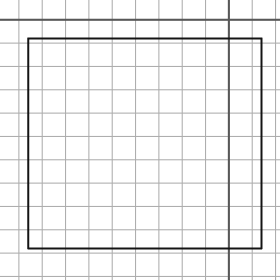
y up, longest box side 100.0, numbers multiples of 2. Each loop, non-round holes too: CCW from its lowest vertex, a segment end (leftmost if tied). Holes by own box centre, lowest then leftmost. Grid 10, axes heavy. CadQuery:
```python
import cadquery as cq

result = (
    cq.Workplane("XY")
    .moveTo(-86.0, -98.0)
    .lineTo(14.0, -98.0)
    .lineTo(14.0, -8.0)
    .lineTo(-86.0, -8.0)
    .close()
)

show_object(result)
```